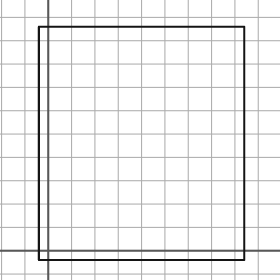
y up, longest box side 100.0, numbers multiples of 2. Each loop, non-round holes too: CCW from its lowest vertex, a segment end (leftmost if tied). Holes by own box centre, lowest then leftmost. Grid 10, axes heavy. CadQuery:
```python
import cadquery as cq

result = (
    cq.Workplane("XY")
    .moveTo(-4.0, -4.0)
    .lineTo(84.0, -4.0)
    .lineTo(84.0, 96.0)
    .lineTo(-4.0, 96.0)
    .close()
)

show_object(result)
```